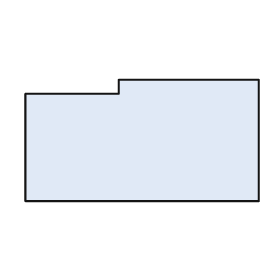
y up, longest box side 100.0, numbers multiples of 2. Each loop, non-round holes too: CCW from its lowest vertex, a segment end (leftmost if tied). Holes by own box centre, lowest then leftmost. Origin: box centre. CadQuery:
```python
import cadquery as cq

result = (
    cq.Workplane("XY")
    .moveTo(-50.0, -26.0)
    .lineTo(50.0, -26.0)
    .lineTo(50.0, 26.0)
    .lineTo(-10.0, 26.0)
    .lineTo(-10.0, 20.0)
    .lineTo(-50.0, 20.0)
    .close()
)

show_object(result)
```